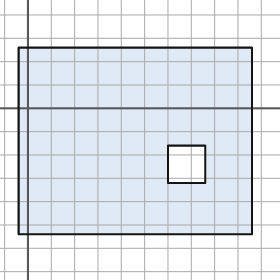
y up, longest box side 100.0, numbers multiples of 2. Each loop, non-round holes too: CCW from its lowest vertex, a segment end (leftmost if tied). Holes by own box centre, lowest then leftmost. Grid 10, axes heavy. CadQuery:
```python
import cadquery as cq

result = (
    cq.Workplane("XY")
    .moveTo(-4.0, -54.0)
    .lineTo(96.0, -54.0)
    .lineTo(96.0, 26.0)
    .lineTo(-4.0, 26.0)
    .close()
    .moveTo(60.0, -32.0)
    .lineTo(76.0, -32.0)
    .lineTo(76.0, -16.0)
    .lineTo(60.0, -16.0)
    .close()
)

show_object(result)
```